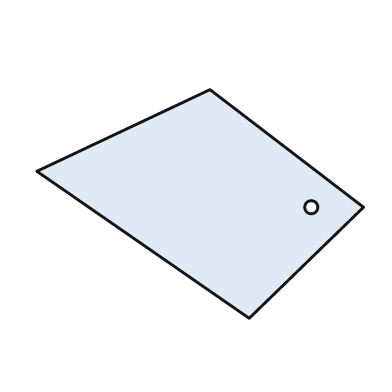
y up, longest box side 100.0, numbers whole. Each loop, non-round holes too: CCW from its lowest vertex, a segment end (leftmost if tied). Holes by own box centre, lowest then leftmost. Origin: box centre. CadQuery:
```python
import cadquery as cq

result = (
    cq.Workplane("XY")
    .moveTo(15.0, -35.0)
    .lineTo(50.0, -1.0)
    .lineTo(3.0, 35.0)
    .lineTo(-50.0, 10.0)
    .close()
    .moveTo(34.0, -1.0)
    .circle(2.0)
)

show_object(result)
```